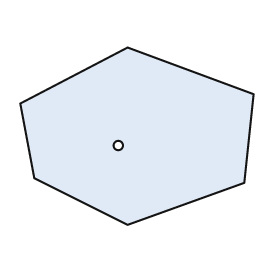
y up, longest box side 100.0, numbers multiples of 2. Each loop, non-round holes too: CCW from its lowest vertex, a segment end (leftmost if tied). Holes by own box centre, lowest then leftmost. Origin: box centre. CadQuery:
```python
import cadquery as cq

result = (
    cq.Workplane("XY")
    .moveTo(-4.0, -38.0)
    .lineTo(46.0, -20.0)
    .lineTo(50.0, 18.0)
    .lineTo(-4.0, 38.0)
    .lineTo(-50.0, 14.0)
    .lineTo(-44.0, -18.0)
    .close()
    .moveTo(-8.0, -4.0)
    .circle(2.0)
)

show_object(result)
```